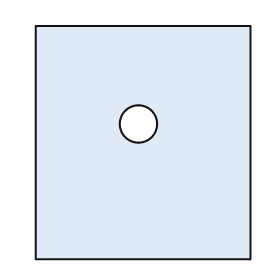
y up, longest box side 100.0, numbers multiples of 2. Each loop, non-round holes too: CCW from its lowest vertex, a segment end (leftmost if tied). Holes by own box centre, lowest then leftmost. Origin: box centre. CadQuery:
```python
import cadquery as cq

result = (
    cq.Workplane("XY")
    .moveTo(-46.0, -50.0)
    .lineTo(46.0, -50.0)
    .lineTo(46.0, 50.0)
    .lineTo(-46.0, 50.0)
    .close()
    .moveTo(-2.0, 8.0)
    .circle(8.0)
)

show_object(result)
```